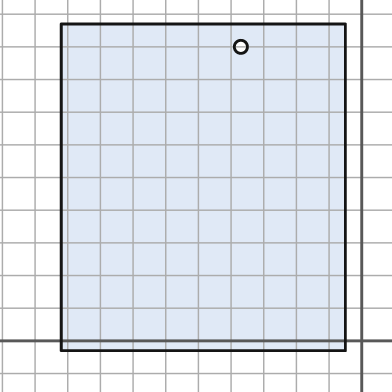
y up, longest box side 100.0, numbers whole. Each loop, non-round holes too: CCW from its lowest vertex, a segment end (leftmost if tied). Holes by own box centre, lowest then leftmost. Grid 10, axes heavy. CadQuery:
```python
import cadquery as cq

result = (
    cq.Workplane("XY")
    .moveTo(-92.0, -3.0)
    .lineTo(-5.0, -3.0)
    .lineTo(-5.0, 97.0)
    .lineTo(-92.0, 97.0)
    .close()
    .moveTo(-37.0, 90.0)
    .circle(2.0)
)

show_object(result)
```